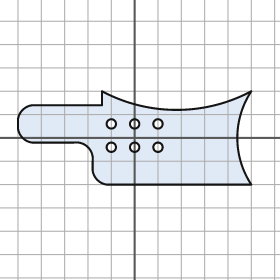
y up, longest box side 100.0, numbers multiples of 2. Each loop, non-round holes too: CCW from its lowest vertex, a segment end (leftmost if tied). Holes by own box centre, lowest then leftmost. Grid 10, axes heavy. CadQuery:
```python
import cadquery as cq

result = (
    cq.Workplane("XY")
    .moveTo(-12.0, -20.0)
    .lineTo(50.0, -20.0)
    .threePointArc((44.0, 0.0), (50.0, 20.0))
    .threePointArc((18.0, 12.0), (-14.0, 20.0))
    .lineTo(-14.0, 14.0)
    .lineTo(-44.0, 14.0)
    .threePointArc((-48.0, 12.0), (-50.0, 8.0))
    .lineTo(-50.0, 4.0)
    .threePointArc((-48.0, 0.0), (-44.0, -2.0))
    .lineTo(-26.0, -2.0)
    .threePointArc((-20.0, -4.0), (-18.0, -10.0))
    .lineTo(-18.0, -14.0)
    .threePointArc((-16.0, -18.0), (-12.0, -20.0))
    .close()
    .moveTo(-10.0, -4.0)
    .circle(2.0)
    .moveTo(0.0, -4.0)
    .circle(2.0)
    .moveTo(10.0, -4.0)
    .circle(2.0)
    .moveTo(-10.0, 6.0)
    .circle(2.0)
    .moveTo(0.0, 6.0)
    .circle(2.0)
    .moveTo(10.0, 6.0)
    .circle(2.0)
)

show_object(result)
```